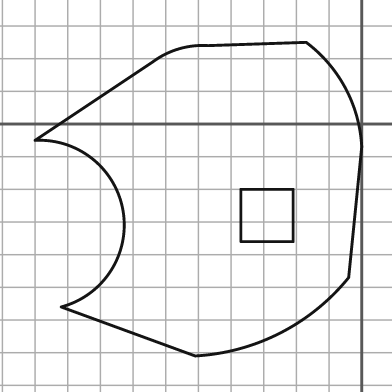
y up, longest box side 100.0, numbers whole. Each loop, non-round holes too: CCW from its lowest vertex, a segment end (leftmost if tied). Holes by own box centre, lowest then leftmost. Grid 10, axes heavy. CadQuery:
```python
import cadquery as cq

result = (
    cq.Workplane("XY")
    .moveTo(-51.0, -71.0)
    .threePointArc((-25.0, -64.0), (-4.0, -47.0))
    .lineTo(0.0, -7.0)
    .threePointArc((-5.0, 11.0), (-17.0, 25.0))
    .lineTo(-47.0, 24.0)
    .threePointArc((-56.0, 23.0), (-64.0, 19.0))
    .lineTo(-100.0, -5.0)
    .threePointArc((-73.0, -27.0), (-92.0, -56.0))
    .close()
    .moveTo(-37.0, -36.0)
    .lineTo(-21.0, -36.0)
    .lineTo(-21.0, -20.0)
    .lineTo(-37.0, -20.0)
    .close()
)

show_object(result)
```